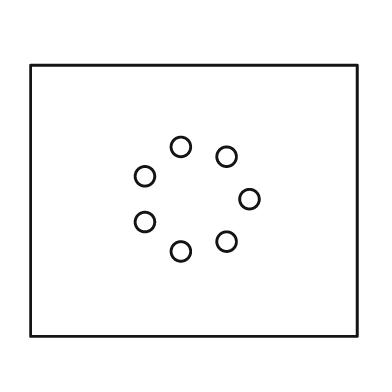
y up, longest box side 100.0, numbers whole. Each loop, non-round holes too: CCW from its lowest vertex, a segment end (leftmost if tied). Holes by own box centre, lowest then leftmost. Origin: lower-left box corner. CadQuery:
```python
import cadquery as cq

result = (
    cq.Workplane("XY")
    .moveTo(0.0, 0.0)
    .lineTo(100.0, 0.0)
    .lineTo(100.0, 83.0)
    .lineTo(0.0, 83.0)
    .close()
    .moveTo(46.0, 26.0)
    .circle(3.0)
    .moveTo(60.0, 29.0)
    .circle(3.0)
    .moveTo(35.0, 35.0)
    .circle(3.0)
    .moveTo(67.0, 42.0)
    .circle(3.0)
    .moveTo(35.0, 49.0)
    .circle(3.0)
    .moveTo(60.0, 55.0)
    .circle(3.0)
    .moveTo(46.0, 58.0)
    .circle(3.0)
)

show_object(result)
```